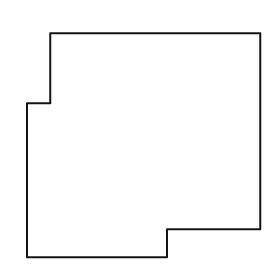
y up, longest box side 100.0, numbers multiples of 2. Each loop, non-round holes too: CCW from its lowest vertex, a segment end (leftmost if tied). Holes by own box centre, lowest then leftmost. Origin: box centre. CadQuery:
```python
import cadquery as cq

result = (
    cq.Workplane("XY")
    .moveTo(-50.0, -48.0)
    .lineTo(10.0, -48.0)
    .lineTo(10.0, -36.0)
    .lineTo(50.0, -36.0)
    .lineTo(50.0, 48.0)
    .lineTo(-40.0, 48.0)
    .lineTo(-40.0, 18.0)
    .lineTo(-50.0, 18.0)
    .close()
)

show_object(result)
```